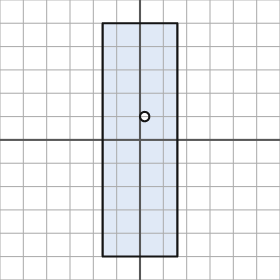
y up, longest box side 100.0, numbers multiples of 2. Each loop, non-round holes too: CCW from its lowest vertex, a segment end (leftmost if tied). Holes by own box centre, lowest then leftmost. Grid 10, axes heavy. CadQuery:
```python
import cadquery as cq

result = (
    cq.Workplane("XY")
    .moveTo(-16.0, -50.0)
    .lineTo(16.0, -50.0)
    .lineTo(16.0, 50.0)
    .lineTo(-16.0, 50.0)
    .close()
    .moveTo(2.0, 10.0)
    .circle(2.0)
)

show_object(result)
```